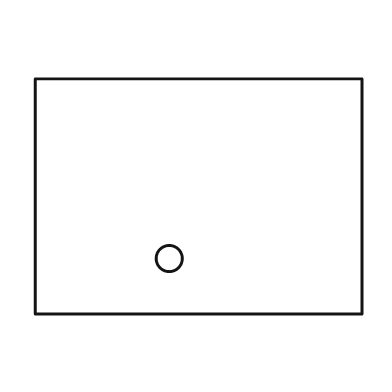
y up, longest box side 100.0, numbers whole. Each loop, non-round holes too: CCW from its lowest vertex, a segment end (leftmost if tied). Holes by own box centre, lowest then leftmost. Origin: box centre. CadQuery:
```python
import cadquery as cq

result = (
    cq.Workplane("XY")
    .moveTo(-50.0, -36.0)
    .lineTo(50.0, -36.0)
    .lineTo(50.0, 36.0)
    .lineTo(-50.0, 36.0)
    .close()
    .moveTo(-9.0, -19.0)
    .circle(4.0)
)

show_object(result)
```